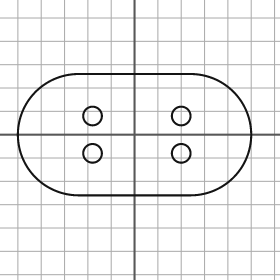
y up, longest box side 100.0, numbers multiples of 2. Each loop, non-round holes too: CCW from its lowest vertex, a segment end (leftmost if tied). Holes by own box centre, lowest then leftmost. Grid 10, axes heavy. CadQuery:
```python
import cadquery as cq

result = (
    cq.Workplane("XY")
    .moveTo(-24.0, -26.0)
    .lineTo(24.0, -26.0)
    .threePointArc((50.0, 0.0), (24.0, 26.0))
    .lineTo(-24.0, 26.0)
    .threePointArc((-50.0, 0.0), (-24.0, -26.0))
    .close()
    .moveTo(-18.0, -8.0)
    .circle(4.0)
    .moveTo(20.0, -8.0)
    .circle(4.0)
    .moveTo(-18.0, 8.0)
    .circle(4.0)
    .moveTo(20.0, 8.0)
    .circle(4.0)
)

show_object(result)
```